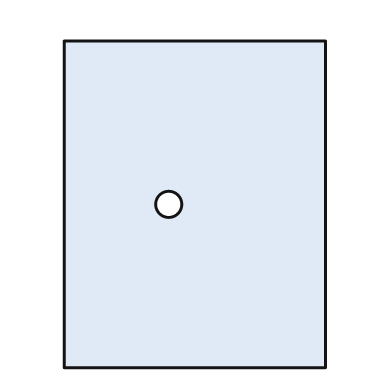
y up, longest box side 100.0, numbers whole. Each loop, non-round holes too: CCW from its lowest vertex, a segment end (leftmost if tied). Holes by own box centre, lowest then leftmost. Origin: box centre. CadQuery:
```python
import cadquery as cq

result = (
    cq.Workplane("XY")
    .moveTo(-40.0, -50.0)
    .lineTo(40.0, -50.0)
    .lineTo(40.0, 50.0)
    .lineTo(-40.0, 50.0)
    .close()
    .moveTo(-8.0, 0.0)
    .circle(4.0)
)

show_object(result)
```